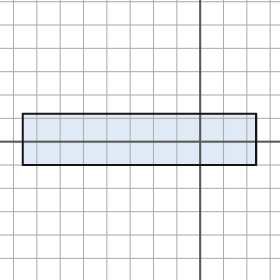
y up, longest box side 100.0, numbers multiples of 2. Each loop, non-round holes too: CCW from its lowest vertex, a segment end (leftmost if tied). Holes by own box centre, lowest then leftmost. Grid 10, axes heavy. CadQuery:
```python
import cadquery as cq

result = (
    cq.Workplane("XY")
    .moveTo(-76.0, -10.0)
    .lineTo(24.0, -10.0)
    .lineTo(24.0, 12.0)
    .lineTo(-76.0, 12.0)
    .close()
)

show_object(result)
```